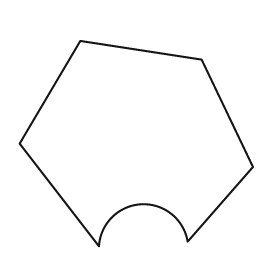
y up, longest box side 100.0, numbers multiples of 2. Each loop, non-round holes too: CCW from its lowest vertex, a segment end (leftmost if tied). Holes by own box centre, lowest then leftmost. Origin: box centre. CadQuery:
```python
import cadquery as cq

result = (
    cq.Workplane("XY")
    .moveTo(-16.0, -44.0)
    .threePointArc((2.0, -26.0), (22.0, -42.0))
    .lineTo(50.0, -10.0)
    .lineTo(28.0, 36.0)
    .lineTo(-24.0, 44.0)
    .lineTo(-50.0, 0.0)
    .close()
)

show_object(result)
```